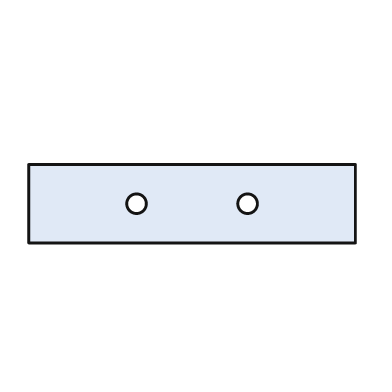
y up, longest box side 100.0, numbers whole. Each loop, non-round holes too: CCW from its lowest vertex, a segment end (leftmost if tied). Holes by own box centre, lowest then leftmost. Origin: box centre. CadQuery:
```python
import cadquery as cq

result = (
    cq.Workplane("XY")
    .moveTo(-50.0, -12.0)
    .lineTo(50.0, -12.0)
    .lineTo(50.0, 12.0)
    .lineTo(-50.0, 12.0)
    .close()
    .moveTo(-17.0, 0.0)
    .circle(3.0)
    .moveTo(17.0, 0.0)
    .circle(3.0)
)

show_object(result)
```